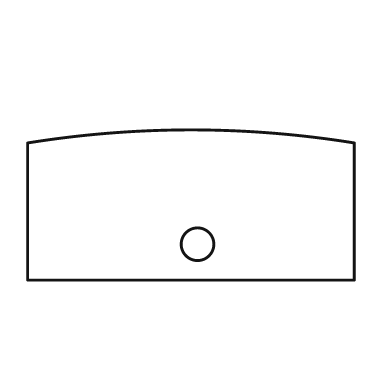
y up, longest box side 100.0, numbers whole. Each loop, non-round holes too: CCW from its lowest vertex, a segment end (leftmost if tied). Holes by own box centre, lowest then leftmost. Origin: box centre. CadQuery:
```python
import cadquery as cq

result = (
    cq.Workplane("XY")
    .moveTo(-50.0, -23.0)
    .lineTo(50.0, -23.0)
    .lineTo(50.0, 19.0)
    .threePointArc((0.0, 23.0), (-50.0, 19.0))
    .close()
    .moveTo(2.0, -12.0)
    .circle(5.0)
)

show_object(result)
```